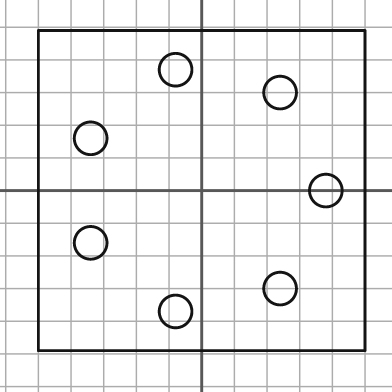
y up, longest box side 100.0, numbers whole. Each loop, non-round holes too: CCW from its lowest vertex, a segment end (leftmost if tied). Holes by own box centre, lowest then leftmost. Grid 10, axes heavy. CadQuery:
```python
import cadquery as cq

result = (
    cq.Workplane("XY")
    .moveTo(-50.0, -49.0)
    .lineTo(50.0, -49.0)
    .lineTo(50.0, 49.0)
    .lineTo(-50.0, 49.0)
    .close()
    .moveTo(-8.0, -37.0)
    .circle(5.0)
    .moveTo(24.0, -30.0)
    .circle(5.0)
    .moveTo(-34.0, -16.0)
    .circle(5.0)
    .moveTo(38.0, 0.0)
    .circle(5.0)
    .moveTo(-34.0, 16.0)
    .circle(5.0)
    .moveTo(24.0, 30.0)
    .circle(5.0)
    .moveTo(-8.0, 37.0)
    .circle(5.0)
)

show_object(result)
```